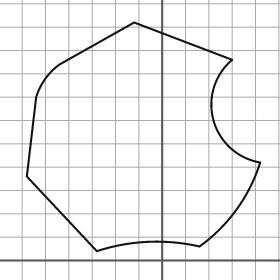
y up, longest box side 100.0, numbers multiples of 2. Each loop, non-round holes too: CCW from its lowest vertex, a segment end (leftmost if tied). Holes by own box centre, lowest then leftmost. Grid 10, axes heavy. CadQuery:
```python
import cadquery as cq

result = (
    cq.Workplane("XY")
    .moveTo(-28.0, 4.0)
    .threePointArc((-6.0, 8.0), (16.0, 6.0))
    .threePointArc((32.0, 22.0), (42.0, 42.0))
    .threePointArc((22.0, 60.0), (30.0, 86.0))
    .lineTo(-12.0, 102.0)
    .lineTo(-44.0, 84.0)
    .threePointArc((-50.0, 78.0), (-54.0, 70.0))
    .lineTo(-58.0, 36.0)
    .close()
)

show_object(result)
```